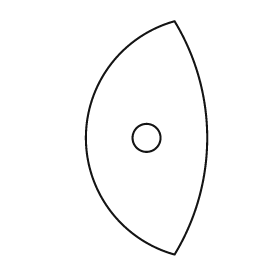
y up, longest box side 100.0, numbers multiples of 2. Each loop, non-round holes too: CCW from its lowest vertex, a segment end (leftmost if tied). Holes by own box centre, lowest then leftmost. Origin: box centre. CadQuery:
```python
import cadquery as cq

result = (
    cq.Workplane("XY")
    .moveTo(12.0, -50.0)
    .threePointArc((26.0, 0.0), (12.0, 50.0))
    .threePointArc((-26.0, 0.0), (12.0, -50.0))
    .close()
    .moveTo(0.0, 0.0)
    .circle(6.0)
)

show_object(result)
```